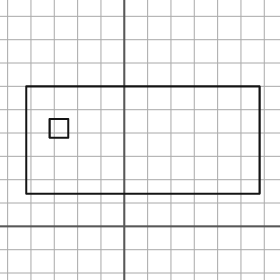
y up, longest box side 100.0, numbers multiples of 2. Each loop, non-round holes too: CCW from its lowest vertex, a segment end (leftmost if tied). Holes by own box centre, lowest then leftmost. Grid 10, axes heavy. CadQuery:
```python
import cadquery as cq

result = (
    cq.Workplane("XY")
    .moveTo(-42.0, 14.0)
    .lineTo(58.0, 14.0)
    .lineTo(58.0, 60.0)
    .lineTo(-42.0, 60.0)
    .close()
    .moveTo(-32.0, 38.0)
    .lineTo(-24.0, 38.0)
    .lineTo(-24.0, 46.0)
    .lineTo(-32.0, 46.0)
    .close()
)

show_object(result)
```